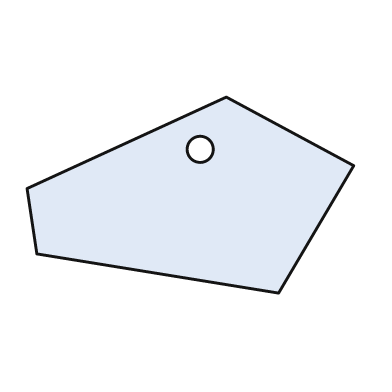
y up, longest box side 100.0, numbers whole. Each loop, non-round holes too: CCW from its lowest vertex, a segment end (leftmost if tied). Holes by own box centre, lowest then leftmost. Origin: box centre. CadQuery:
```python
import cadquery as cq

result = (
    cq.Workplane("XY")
    .moveTo(27.0, -30.0)
    .lineTo(50.0, 9.0)
    .lineTo(11.0, 30.0)
    .lineTo(-50.0, 2.0)
    .lineTo(-47.0, -18.0)
    .close()
    .moveTo(3.0, 14.0)
    .circle(4.0)
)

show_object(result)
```